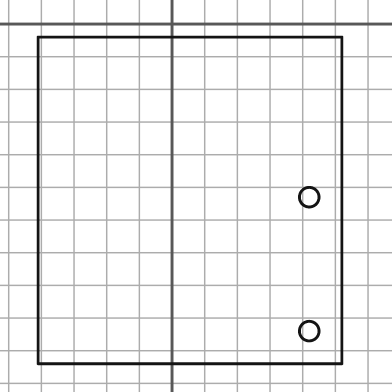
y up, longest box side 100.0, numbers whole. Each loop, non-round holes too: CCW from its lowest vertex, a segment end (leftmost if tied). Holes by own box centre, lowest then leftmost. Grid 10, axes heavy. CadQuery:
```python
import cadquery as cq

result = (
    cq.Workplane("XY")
    .moveTo(-41.0, -104.0)
    .lineTo(52.0, -104.0)
    .lineTo(52.0, -4.0)
    .lineTo(-41.0, -4.0)
    .close()
    .moveTo(42.0, -94.0)
    .circle(3.0)
    .moveTo(42.0, -53.0)
    .circle(3.0)
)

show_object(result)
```